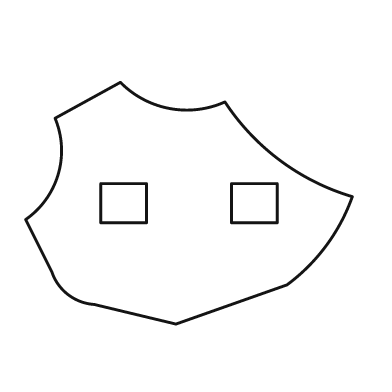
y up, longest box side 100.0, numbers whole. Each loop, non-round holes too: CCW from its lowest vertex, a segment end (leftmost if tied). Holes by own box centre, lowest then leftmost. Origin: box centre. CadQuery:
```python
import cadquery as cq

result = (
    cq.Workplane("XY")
    .moveTo(-4.0, -37.0)
    .lineTo(30.0, -25.0)
    .threePointArc((42.0, -13.0), (50.0, 2.0))
    .threePointArc((28.0, 13.0), (11.0, 31.0))
    .threePointArc((-6.0, 29.0), (-21.0, 37.0))
    .lineTo(-41.0, 26.0)
    .threePointArc((-40.0, 9.0), (-50.0, -5.0))
    .lineTo(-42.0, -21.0)
    .threePointArc((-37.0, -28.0), (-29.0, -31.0))
    .close()
    .moveTo(-27.0, -6.0)
    .lineTo(-13.0, -6.0)
    .lineTo(-13.0, 6.0)
    .lineTo(-27.0, 6.0)
    .close()
    .moveTo(13.0, -6.0)
    .lineTo(27.0, -6.0)
    .lineTo(27.0, 6.0)
    .lineTo(13.0, 6.0)
    .close()
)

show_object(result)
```